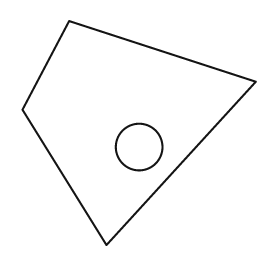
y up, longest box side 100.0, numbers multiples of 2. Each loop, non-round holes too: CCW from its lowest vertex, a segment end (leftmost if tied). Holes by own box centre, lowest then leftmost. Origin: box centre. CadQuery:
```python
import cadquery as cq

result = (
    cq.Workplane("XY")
    .moveTo(-14.0, -48.0)
    .lineTo(50.0, 22.0)
    .lineTo(-30.0, 48.0)
    .lineTo(-50.0, 10.0)
    .close()
    .moveTo(0.0, -6.0)
    .circle(10.0)
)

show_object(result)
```